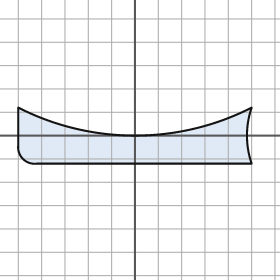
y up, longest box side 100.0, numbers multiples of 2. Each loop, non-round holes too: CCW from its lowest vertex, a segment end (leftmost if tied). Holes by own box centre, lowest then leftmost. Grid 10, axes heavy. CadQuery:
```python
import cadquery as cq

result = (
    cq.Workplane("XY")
    .moveTo(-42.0, -12.0)
    .lineTo(50.0, -12.0)
    .threePointArc((48.0, 0.0), (50.0, 12.0))
    .threePointArc((0.0, 0.0), (-50.0, 12.0))
    .lineTo(-50.0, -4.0)
    .threePointArc((-48.0, -10.0), (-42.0, -12.0))
    .close()
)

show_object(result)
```